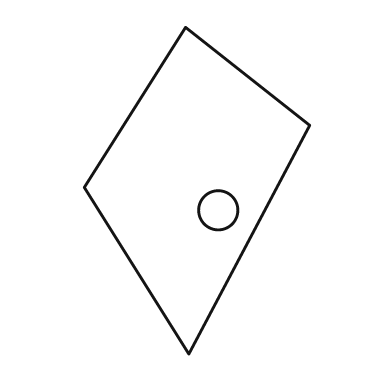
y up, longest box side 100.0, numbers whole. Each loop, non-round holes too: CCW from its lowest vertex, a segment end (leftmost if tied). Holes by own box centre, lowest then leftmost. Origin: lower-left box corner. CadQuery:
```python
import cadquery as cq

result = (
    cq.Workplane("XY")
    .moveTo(32.0, 0.0)
    .lineTo(69.0, 70.0)
    .lineTo(31.0, 100.0)
    .lineTo(0.0, 51.0)
    .close()
    .moveTo(41.0, 44.0)
    .circle(6.0)
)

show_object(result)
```